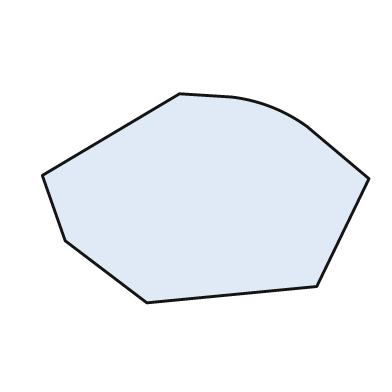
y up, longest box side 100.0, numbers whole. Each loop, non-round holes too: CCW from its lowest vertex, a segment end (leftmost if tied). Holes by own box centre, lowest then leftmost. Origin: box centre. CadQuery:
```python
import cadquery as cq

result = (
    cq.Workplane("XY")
    .moveTo(-18.0, -32.0)
    .lineTo(34.0, -27.0)
    .lineTo(50.0, 6.0)
    .lineTo(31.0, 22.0)
    .threePointArc((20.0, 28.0), (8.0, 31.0))
    .lineTo(-8.0, 32.0)
    .lineTo(-50.0, 7.0)
    .lineTo(-43.0, -13.0)
    .close()
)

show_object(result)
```